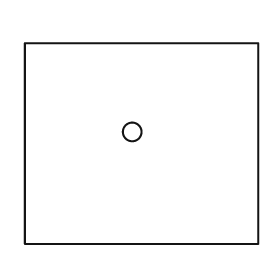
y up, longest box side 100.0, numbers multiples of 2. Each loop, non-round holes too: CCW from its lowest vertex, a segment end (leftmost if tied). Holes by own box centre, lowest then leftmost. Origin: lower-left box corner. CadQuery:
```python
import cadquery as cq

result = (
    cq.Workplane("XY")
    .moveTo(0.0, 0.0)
    .lineTo(100.0, 0.0)
    .lineTo(100.0, 86.0)
    .lineTo(0.0, 86.0)
    .close()
    .moveTo(46.0, 48.0)
    .circle(4.0)
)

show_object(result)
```